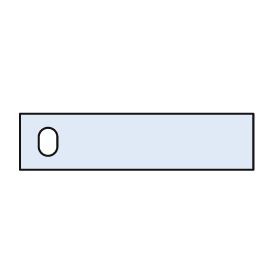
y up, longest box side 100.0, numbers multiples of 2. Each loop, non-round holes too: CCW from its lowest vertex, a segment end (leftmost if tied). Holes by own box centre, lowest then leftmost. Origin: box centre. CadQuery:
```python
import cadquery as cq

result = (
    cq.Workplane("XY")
    .moveTo(-50.0, -12.0)
    .lineTo(50.0, -12.0)
    .lineTo(50.0, 12.0)
    .lineTo(-50.0, 12.0)
    .close()
    .moveTo(-42.0, -2.0)
    .threePointArc((-38.0, -6.0), (-34.0, -2.0))
    .lineTo(-34.0, 2.0)
    .threePointArc((-38.0, 6.0), (-42.0, 2.0))
    .close()
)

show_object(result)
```